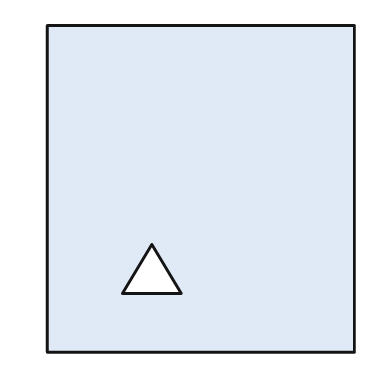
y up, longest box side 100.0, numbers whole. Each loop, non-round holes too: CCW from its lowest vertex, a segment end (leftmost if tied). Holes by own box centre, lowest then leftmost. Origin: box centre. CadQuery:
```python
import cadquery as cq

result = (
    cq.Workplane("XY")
    .moveTo(-47.0, -50.0)
    .lineTo(47.0, -50.0)
    .lineTo(47.0, 50.0)
    .lineTo(-47.0, 50.0)
    .close()
    .moveTo(-24.0, -32.0)
    .lineTo(-6.0, -32.0)
    .lineTo(-15.0, -17.0)
    .close()
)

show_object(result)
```